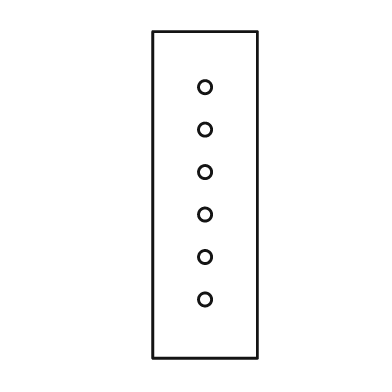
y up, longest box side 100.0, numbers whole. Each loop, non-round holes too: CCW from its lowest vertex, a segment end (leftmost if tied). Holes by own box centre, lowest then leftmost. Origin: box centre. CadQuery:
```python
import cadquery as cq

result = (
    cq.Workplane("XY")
    .moveTo(-16.0, -50.0)
    .lineTo(16.0, -50.0)
    .lineTo(16.0, 50.0)
    .lineTo(-16.0, 50.0)
    .close()
    .moveTo(0.0, -32.0)
    .circle(2.0)
    .moveTo(0.0, -19.0)
    .circle(2.0)
    .moveTo(0.0, -6.0)
    .circle(2.0)
    .moveTo(0.0, 7.0)
    .circle(2.0)
    .moveTo(0.0, 20.0)
    .circle(2.0)
    .moveTo(0.0, 33.0)
    .circle(2.0)
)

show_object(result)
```